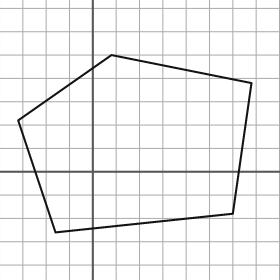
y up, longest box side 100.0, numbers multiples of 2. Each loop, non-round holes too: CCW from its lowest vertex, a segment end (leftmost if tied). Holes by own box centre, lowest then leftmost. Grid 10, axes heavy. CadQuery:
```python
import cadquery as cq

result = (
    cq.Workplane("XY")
    .moveTo(-16.0, -26.0)
    .lineTo(60.0, -18.0)
    .lineTo(68.0, 38.0)
    .lineTo(8.0, 50.0)
    .lineTo(-32.0, 22.0)
    .close()
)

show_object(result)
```